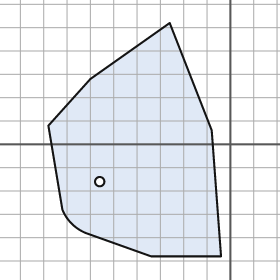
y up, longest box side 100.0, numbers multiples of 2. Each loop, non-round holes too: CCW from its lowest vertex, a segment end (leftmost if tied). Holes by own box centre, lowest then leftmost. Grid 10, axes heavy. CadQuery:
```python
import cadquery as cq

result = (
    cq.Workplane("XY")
    .moveTo(-34.0, -48.0)
    .lineTo(-4.0, -48.0)
    .lineTo(-8.0, 6.0)
    .lineTo(-26.0, 52.0)
    .lineTo(-60.0, 28.0)
    .lineTo(-78.0, 8.0)
    .lineTo(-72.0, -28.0)
    .threePointArc((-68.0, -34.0), (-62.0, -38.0))
    .close()
    .moveTo(-56.0, -16.0)
    .circle(2.0)
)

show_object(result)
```